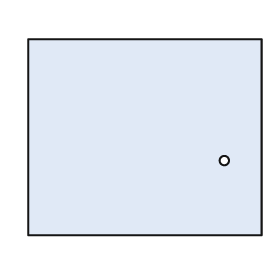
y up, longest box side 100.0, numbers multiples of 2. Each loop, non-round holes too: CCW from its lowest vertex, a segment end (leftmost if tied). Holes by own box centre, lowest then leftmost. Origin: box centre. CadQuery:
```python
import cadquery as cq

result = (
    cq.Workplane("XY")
    .moveTo(-50.0, -42.0)
    .lineTo(50.0, -42.0)
    .lineTo(50.0, 42.0)
    .lineTo(-50.0, 42.0)
    .close()
    .moveTo(34.0, -10.0)
    .circle(2.0)
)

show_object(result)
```